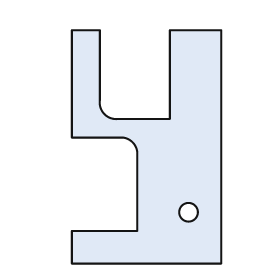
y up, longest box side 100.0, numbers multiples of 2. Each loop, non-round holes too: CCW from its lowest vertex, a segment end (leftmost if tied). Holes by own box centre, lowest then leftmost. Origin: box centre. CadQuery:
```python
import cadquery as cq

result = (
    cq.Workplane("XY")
    .moveTo(-32.0, -50.0)
    .lineTo(32.0, -50.0)
    .lineTo(32.0, 50.0)
    .lineTo(10.0, 50.0)
    .lineTo(10.0, 12.0)
    .lineTo(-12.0, 12.0)
    .threePointArc((-18.0, 14.0), (-20.0, 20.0))
    .lineTo(-20.0, 50.0)
    .lineTo(-32.0, 50.0)
    .lineTo(-32.0, 4.0)
    .lineTo(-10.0, 4.0)
    .threePointArc((-6.0, 2.0), (-4.0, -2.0))
    .lineTo(-4.0, -36.0)
    .lineTo(-32.0, -36.0)
    .close()
    .moveTo(18.0, -28.0)
    .circle(4.0)
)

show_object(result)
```